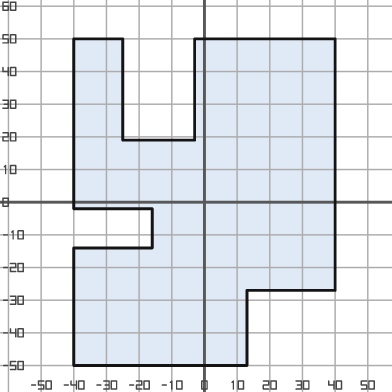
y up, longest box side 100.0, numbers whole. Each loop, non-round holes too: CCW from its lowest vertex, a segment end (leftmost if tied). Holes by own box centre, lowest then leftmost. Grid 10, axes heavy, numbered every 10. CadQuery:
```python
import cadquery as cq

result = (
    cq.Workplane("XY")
    .moveTo(-40.0, -50.0)
    .lineTo(13.0, -50.0)
    .lineTo(13.0, -27.0)
    .lineTo(40.0, -27.0)
    .lineTo(40.0, 50.0)
    .lineTo(-3.0, 50.0)
    .lineTo(-3.0, 19.0)
    .lineTo(-25.0, 19.0)
    .lineTo(-25.0, 50.0)
    .lineTo(-40.0, 50.0)
    .lineTo(-40.0, -2.0)
    .lineTo(-16.0, -2.0)
    .lineTo(-16.0, -14.0)
    .lineTo(-40.0, -14.0)
    .close()
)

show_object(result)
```